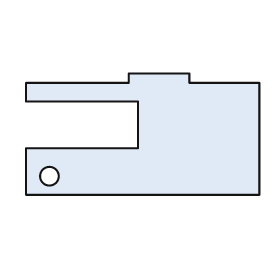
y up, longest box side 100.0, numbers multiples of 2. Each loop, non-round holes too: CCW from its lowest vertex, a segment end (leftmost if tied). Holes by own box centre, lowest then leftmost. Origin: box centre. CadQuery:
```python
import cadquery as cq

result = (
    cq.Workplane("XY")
    .moveTo(-50.0, -26.0)
    .lineTo(50.0, -26.0)
    .lineTo(50.0, 22.0)
    .lineTo(20.0, 22.0)
    .lineTo(20.0, 26.0)
    .lineTo(-6.0, 26.0)
    .lineTo(-6.0, 22.0)
    .lineTo(-50.0, 22.0)
    .lineTo(-50.0, 14.0)
    .lineTo(-2.0, 14.0)
    .lineTo(-2.0, -6.0)
    .lineTo(-50.0, -6.0)
    .close()
    .moveTo(-40.0, -18.0)
    .circle(4.0)
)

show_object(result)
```